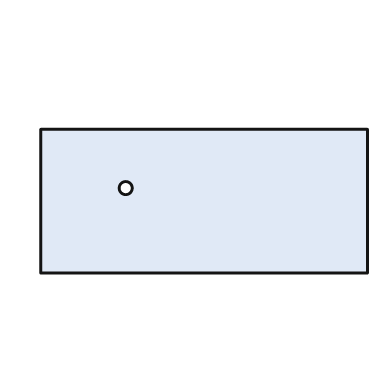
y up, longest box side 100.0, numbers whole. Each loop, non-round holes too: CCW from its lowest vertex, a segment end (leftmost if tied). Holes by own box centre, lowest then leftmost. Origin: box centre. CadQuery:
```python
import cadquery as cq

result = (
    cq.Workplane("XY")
    .moveTo(-50.0, -22.0)
    .lineTo(50.0, -22.0)
    .lineTo(50.0, 22.0)
    .lineTo(-50.0, 22.0)
    .close()
    .moveTo(-24.0, 4.0)
    .circle(2.0)
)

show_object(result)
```